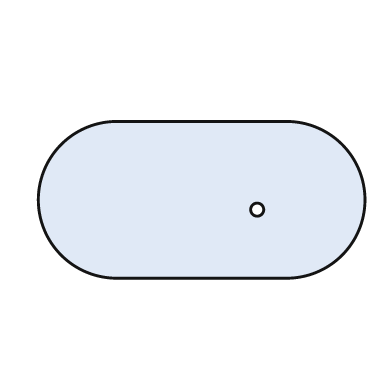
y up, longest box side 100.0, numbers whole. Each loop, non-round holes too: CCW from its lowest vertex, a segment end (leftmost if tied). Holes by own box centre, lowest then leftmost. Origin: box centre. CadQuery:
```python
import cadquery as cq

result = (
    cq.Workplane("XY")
    .moveTo(-26.0, -24.0)
    .lineTo(26.0, -24.0)
    .threePointArc((50.0, 0.0), (26.0, 24.0))
    .lineTo(-26.0, 24.0)
    .threePointArc((-50.0, 0.0), (-26.0, -24.0))
    .close()
    .moveTo(17.0, -3.0)
    .circle(2.0)
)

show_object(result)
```